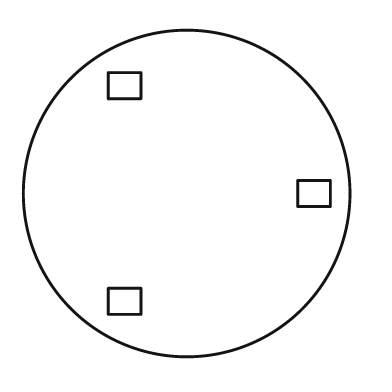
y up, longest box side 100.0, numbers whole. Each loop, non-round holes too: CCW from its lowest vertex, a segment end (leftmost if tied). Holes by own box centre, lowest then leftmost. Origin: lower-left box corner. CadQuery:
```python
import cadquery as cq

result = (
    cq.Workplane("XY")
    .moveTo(50.0, 50.0)
    .circle(50.0)
    .moveTo(26.0, 13.0)
    .lineTo(36.0, 13.0)
    .lineTo(36.0, 21.0)
    .lineTo(26.0, 21.0)
    .close()
    .moveTo(84.0, 46.0)
    .lineTo(94.0, 46.0)
    .lineTo(94.0, 54.0)
    .lineTo(84.0, 54.0)
    .close()
    .moveTo(26.0, 79.0)
    .lineTo(36.0, 79.0)
    .lineTo(36.0, 87.0)
    .lineTo(26.0, 87.0)
    .close()
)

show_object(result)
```